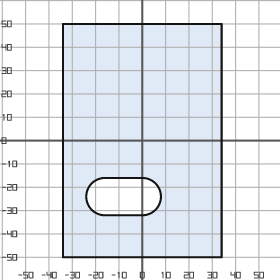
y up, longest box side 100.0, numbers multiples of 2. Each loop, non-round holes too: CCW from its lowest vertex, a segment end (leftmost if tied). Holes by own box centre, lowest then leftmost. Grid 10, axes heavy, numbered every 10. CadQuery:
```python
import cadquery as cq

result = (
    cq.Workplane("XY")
    .moveTo(-34.0, -50.0)
    .lineTo(34.0, -50.0)
    .lineTo(34.0, 50.0)
    .lineTo(-34.0, 50.0)
    .close()
    .moveTo(-16.0, -32.0)
    .lineTo(0.0, -32.0)
    .threePointArc((8.0, -24.0), (0.0, -16.0))
    .lineTo(-16.0, -16.0)
    .threePointArc((-24.0, -24.0), (-16.0, -32.0))
    .close()
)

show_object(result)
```